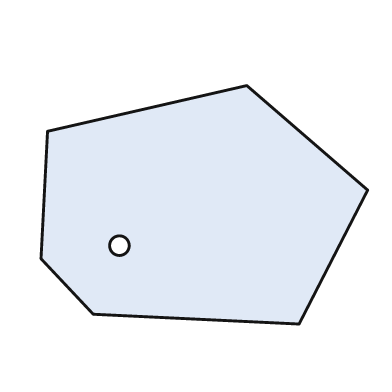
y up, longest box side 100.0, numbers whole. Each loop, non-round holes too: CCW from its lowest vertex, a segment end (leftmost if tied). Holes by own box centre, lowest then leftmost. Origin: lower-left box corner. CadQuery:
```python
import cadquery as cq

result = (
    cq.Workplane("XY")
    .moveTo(79.0, 0.0)
    .lineTo(100.0, 41.0)
    .lineTo(63.0, 73.0)
    .lineTo(2.0, 59.0)
    .lineTo(0.0, 20.0)
    .lineTo(16.0, 3.0)
    .close()
    .moveTo(24.0, 24.0)
    .circle(3.0)
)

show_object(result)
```